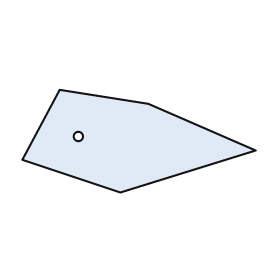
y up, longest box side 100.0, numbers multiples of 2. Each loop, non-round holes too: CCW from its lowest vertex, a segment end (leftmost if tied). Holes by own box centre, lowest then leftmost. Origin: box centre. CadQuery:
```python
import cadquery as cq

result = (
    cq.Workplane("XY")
    .moveTo(-8.0, -22.0)
    .lineTo(50.0, -4.0)
    .lineTo(4.0, 16.0)
    .lineTo(-34.0, 22.0)
    .lineTo(-50.0, -8.0)
    .close()
    .moveTo(-26.0, 2.0)
    .circle(2.0)
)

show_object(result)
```